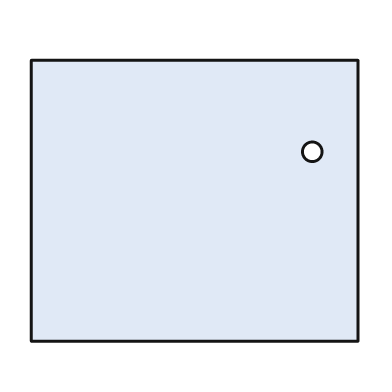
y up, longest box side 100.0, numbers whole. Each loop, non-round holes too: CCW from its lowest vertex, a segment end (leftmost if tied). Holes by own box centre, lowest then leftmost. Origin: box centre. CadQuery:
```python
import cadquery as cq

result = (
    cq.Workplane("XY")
    .moveTo(-50.0, -43.0)
    .lineTo(50.0, -43.0)
    .lineTo(50.0, 43.0)
    .lineTo(-50.0, 43.0)
    .close()
    .moveTo(36.0, 15.0)
    .circle(3.0)
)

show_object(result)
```